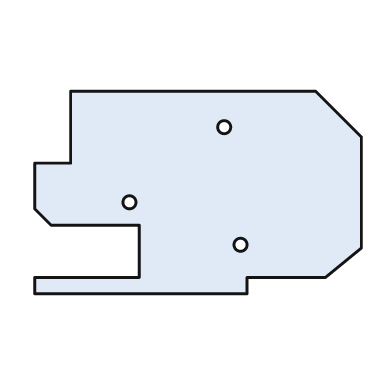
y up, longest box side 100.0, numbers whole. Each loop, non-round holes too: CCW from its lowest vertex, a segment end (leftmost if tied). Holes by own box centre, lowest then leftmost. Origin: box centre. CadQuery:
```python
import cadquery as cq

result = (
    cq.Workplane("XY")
    .moveTo(-50.0, -31.0)
    .lineTo(15.0, -31.0)
    .lineTo(15.0, -26.0)
    .lineTo(39.0, -26.0)
    .lineTo(50.0, -17.0)
    .lineTo(50.0, 17.0)
    .lineTo(36.0, 31.0)
    .lineTo(-39.0, 31.0)
    .lineTo(-39.0, 9.0)
    .lineTo(-50.0, 9.0)
    .lineTo(-50.0, -5.0)
    .lineTo(-45.0, -10.0)
    .lineTo(-18.0, -10.0)
    .lineTo(-18.0, -26.0)
    .lineTo(-50.0, -26.0)
    .close()
    .moveTo(13.0, -16.0)
    .circle(2.0)
    .moveTo(-21.0, -3.0)
    .circle(2.0)
    .moveTo(8.0, 20.0)
    .circle(2.0)
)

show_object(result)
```